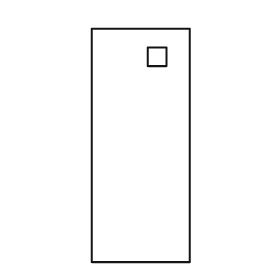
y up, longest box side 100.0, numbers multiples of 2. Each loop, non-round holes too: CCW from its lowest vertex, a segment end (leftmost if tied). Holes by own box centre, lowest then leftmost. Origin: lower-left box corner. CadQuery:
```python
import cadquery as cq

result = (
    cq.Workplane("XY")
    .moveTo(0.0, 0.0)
    .lineTo(42.0, 0.0)
    .lineTo(42.0, 100.0)
    .lineTo(0.0, 100.0)
    .close()
    .moveTo(24.0, 84.0)
    .lineTo(32.0, 84.0)
    .lineTo(32.0, 92.0)
    .lineTo(24.0, 92.0)
    .close()
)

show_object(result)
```